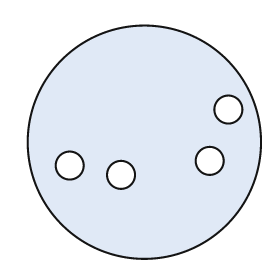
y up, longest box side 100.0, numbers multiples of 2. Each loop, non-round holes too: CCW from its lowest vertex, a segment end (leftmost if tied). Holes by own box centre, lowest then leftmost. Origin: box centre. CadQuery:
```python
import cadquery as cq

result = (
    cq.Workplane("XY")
    .moveTo(0.0, 0.0)
    .circle(50.0)
    .moveTo(-10.0, -14.0)
    .circle(6.0)
    .moveTo(-32.0, -10.0)
    .circle(6.0)
    .moveTo(28.0, -8.0)
    .circle(6.0)
    .moveTo(36.0, 14.0)
    .circle(6.0)
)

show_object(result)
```